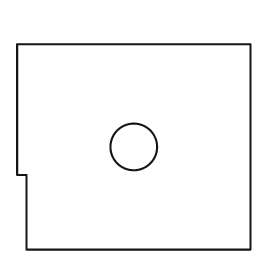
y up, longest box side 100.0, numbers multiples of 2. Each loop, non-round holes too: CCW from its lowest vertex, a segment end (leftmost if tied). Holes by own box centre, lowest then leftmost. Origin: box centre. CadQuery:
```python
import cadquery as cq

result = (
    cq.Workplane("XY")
    .moveTo(-46.0, -44.0)
    .lineTo(50.0, -44.0)
    .lineTo(50.0, 44.0)
    .lineTo(-50.0, 44.0)
    .lineTo(-50.0, -12.0)
    .lineTo(-46.0, -12.0)
    .close()
    .moveTo(0.0, 0.0)
    .circle(10.0)
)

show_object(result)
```